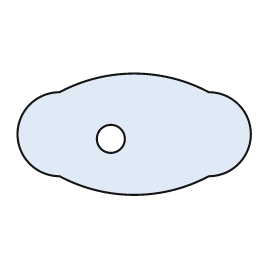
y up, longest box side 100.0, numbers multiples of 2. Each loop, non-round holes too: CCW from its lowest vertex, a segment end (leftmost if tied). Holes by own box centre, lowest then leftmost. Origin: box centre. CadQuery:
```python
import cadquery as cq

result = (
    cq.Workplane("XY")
    .moveTo(-32.0, -18.0)
    .threePointArc((0.0, -26.0), (32.0, -18.0))
    .threePointArc((50.0, 0.0), (32.0, 18.0))
    .threePointArc((0.0, 26.0), (-32.0, 18.0))
    .threePointArc((-50.0, 0.0), (-32.0, -18.0))
    .close()
    .moveTo(-10.0, -2.0)
    .circle(6.0)
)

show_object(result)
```